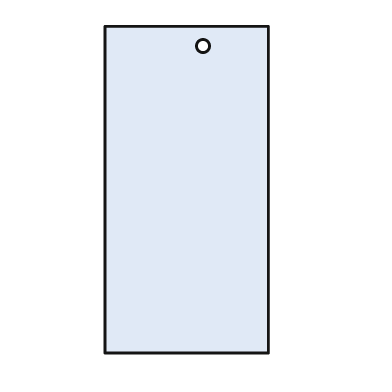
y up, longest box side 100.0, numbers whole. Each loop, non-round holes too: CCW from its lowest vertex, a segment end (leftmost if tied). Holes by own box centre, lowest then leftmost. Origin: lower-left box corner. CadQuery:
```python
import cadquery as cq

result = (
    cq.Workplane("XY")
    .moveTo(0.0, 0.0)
    .lineTo(50.0, 0.0)
    .lineTo(50.0, 100.0)
    .lineTo(0.0, 100.0)
    .close()
    .moveTo(30.0, 94.0)
    .circle(2.0)
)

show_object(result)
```